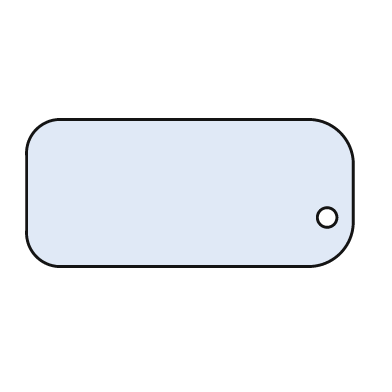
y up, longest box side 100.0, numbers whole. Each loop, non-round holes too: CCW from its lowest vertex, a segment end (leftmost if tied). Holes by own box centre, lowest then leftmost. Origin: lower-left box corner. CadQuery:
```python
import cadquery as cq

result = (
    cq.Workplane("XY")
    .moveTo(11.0, 0.0)
    .lineTo(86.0, 0.0)
    .threePointArc((96.0, 4.0), (100.0, 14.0))
    .lineTo(100.0, 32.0)
    .threePointArc((96.0, 41.0), (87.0, 45.0))
    .lineTo(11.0, 45.0)
    .threePointArc((3.0, 42.0), (0.0, 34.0))
    .lineTo(0.0, 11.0)
    .threePointArc((3.0, 3.0), (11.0, 0.0))
    .close()
    .moveTo(92.0, 15.0)
    .circle(3.0)
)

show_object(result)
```